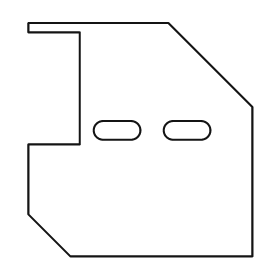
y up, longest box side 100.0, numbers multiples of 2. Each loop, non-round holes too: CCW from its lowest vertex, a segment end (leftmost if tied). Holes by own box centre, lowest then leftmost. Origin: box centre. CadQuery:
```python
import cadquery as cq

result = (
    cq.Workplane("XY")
    .moveTo(-30.0, -50.0)
    .lineTo(48.0, -50.0)
    .lineTo(48.0, 14.0)
    .lineTo(12.0, 50.0)
    .lineTo(-48.0, 50.0)
    .lineTo(-48.0, 46.0)
    .lineTo(-26.0, 46.0)
    .lineTo(-26.0, -2.0)
    .lineTo(-48.0, -2.0)
    .lineTo(-48.0, -32.0)
    .close()
    .moveTo(-16.0, 0.0)
    .lineTo(-4.0, 0.0)
    .threePointArc((0.0, 4.0), (-4.0, 8.0))
    .lineTo(-16.0, 8.0)
    .threePointArc((-20.0, 4.0), (-16.0, 0.0))
    .close()
    .moveTo(14.0, 0.0)
    .lineTo(26.0, 0.0)
    .threePointArc((30.0, 4.0), (26.0, 8.0))
    .lineTo(14.0, 8.0)
    .threePointArc((10.0, 4.0), (14.0, 0.0))
    .close()
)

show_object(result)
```